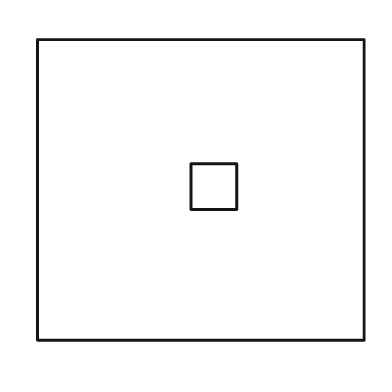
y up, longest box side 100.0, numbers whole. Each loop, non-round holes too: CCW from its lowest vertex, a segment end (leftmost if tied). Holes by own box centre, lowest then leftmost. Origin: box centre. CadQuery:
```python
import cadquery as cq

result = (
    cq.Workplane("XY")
    .moveTo(-50.0, -46.0)
    .lineTo(50.0, -46.0)
    .lineTo(50.0, 46.0)
    .lineTo(-50.0, 46.0)
    .close()
    .moveTo(-3.0, -6.0)
    .lineTo(11.0, -6.0)
    .lineTo(11.0, 8.0)
    .lineTo(-3.0, 8.0)
    .close()
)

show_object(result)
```